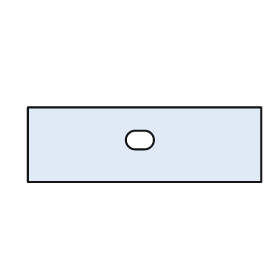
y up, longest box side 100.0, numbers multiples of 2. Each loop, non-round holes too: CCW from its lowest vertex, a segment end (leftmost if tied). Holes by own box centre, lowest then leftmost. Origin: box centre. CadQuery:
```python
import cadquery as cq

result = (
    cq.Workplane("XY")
    .moveTo(-50.0, -16.0)
    .lineTo(50.0, -16.0)
    .lineTo(50.0, 16.0)
    .lineTo(-50.0, 16.0)
    .close()
    .moveTo(-4.0, -2.0)
    .lineTo(0.0, -2.0)
    .threePointArc((4.0, 2.0), (0.0, 6.0))
    .lineTo(-4.0, 6.0)
    .threePointArc((-8.0, 2.0), (-4.0, -2.0))
    .close()
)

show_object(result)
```